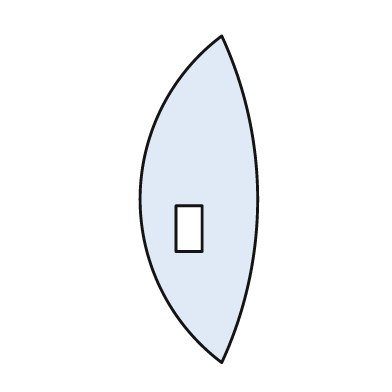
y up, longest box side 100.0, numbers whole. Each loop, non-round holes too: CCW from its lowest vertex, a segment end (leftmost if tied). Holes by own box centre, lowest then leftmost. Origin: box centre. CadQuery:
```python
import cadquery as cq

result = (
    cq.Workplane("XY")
    .moveTo(7.0, -50.0)
    .threePointArc((18.0, 0.0), (7.0, 50.0))
    .threePointArc((-18.0, 0.0), (7.0, -50.0))
    .close()
    .moveTo(-7.0, -16.0)
    .lineTo(1.0, -16.0)
    .lineTo(1.0, -2.0)
    .lineTo(-7.0, -2.0)
    .close()
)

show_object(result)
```